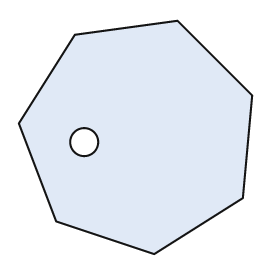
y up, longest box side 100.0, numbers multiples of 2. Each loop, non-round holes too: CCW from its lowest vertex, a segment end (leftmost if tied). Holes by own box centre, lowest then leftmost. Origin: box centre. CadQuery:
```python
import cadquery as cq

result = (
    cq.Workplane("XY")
    .moveTo(8.0, -50.0)
    .lineTo(46.0, -26.0)
    .lineTo(50.0, 18.0)
    .lineTo(18.0, 50.0)
    .lineTo(-26.0, 44.0)
    .lineTo(-50.0, 6.0)
    .lineTo(-34.0, -36.0)
    .close()
    .moveTo(-22.0, -2.0)
    .circle(6.0)
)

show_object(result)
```